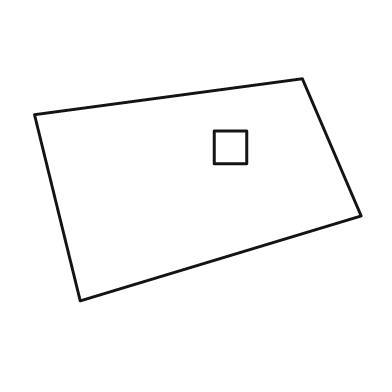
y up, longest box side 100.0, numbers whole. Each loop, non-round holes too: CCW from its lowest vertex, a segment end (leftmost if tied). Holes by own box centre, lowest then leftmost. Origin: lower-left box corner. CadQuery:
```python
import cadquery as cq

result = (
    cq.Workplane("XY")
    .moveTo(14.0, 0.0)
    .lineTo(100.0, 26.0)
    .lineTo(82.0, 68.0)
    .lineTo(0.0, 57.0)
    .close()
    .moveTo(55.0, 42.0)
    .lineTo(65.0, 42.0)
    .lineTo(65.0, 52.0)
    .lineTo(55.0, 52.0)
    .close()
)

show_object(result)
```